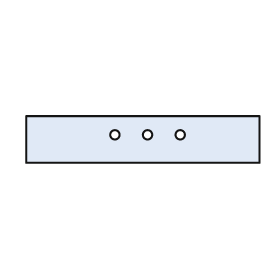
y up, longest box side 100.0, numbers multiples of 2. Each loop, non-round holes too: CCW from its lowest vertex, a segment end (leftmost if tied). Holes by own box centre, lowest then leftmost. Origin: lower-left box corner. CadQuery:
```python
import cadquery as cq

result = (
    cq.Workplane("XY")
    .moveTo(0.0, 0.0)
    .lineTo(100.0, 0.0)
    .lineTo(100.0, 20.0)
    .lineTo(0.0, 20.0)
    .close()
    .moveTo(38.0, 12.0)
    .circle(2.0)
    .moveTo(52.0, 12.0)
    .circle(2.0)
    .moveTo(66.0, 12.0)
    .circle(2.0)
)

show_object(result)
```